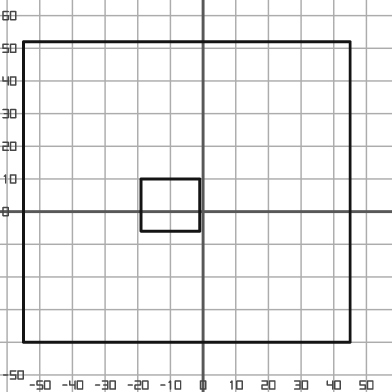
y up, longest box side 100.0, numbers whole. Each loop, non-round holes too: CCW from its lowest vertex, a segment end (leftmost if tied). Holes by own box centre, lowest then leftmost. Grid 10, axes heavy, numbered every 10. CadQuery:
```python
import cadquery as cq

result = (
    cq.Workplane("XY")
    .moveTo(-55.0, -40.0)
    .lineTo(45.0, -40.0)
    .lineTo(45.0, 52.0)
    .lineTo(-55.0, 52.0)
    .close()
    .moveTo(-19.0, -6.0)
    .lineTo(-1.0, -6.0)
    .lineTo(-1.0, 10.0)
    .lineTo(-19.0, 10.0)
    .close()
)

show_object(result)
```